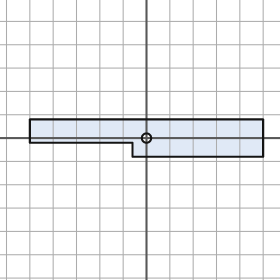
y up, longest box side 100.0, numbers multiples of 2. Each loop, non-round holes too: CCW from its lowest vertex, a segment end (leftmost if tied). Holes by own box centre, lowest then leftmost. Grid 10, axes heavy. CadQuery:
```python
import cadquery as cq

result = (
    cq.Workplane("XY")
    .moveTo(-6.0, -8.0)
    .lineTo(50.0, -8.0)
    .lineTo(50.0, 8.0)
    .lineTo(-50.0, 8.0)
    .lineTo(-50.0, -2.0)
    .lineTo(-6.0, -2.0)
    .close()
    .moveTo(0.0, 0.0)
    .circle(2.0)
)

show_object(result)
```